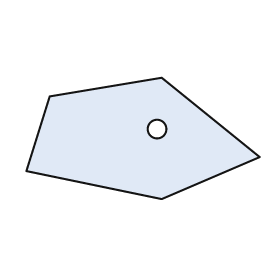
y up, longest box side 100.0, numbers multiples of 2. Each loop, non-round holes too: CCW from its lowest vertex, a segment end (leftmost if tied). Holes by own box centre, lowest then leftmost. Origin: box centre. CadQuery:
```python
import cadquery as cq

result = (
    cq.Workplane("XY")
    .moveTo(8.0, -26.0)
    .lineTo(50.0, -8.0)
    .lineTo(8.0, 26.0)
    .lineTo(-40.0, 18.0)
    .lineTo(-50.0, -14.0)
    .close()
    .moveTo(6.0, 4.0)
    .circle(4.0)
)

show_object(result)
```